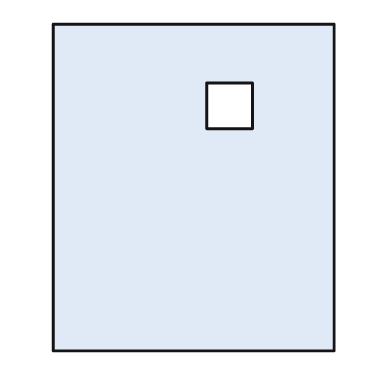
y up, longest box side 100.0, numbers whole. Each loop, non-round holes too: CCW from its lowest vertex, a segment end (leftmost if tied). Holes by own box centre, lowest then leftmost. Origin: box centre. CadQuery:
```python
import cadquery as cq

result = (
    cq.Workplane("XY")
    .moveTo(-43.0, -50.0)
    .lineTo(43.0, -50.0)
    .lineTo(43.0, 50.0)
    .lineTo(-43.0, 50.0)
    .close()
    .moveTo(4.0, 18.0)
    .lineTo(18.0, 18.0)
    .lineTo(18.0, 32.0)
    .lineTo(4.0, 32.0)
    .close()
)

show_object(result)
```